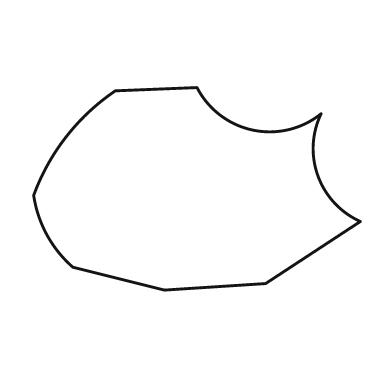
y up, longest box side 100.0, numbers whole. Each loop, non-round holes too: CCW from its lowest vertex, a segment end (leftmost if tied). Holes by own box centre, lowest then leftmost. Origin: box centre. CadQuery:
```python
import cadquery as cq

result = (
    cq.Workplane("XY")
    .moveTo(-10.0, -31.0)
    .lineTo(21.0, -29.0)
    .lineTo(50.0, -10.0)
    .threePointArc((37.0, 4.0), (38.0, 23.0))
    .threePointArc((17.0, 18.0), (0.0, 31.0))
    .lineTo(-25.0, 30.0)
    .threePointArc((-40.0, 16.0), (-50.0, -2.0))
    .threePointArc((-46.0, -14.0), (-38.0, -24.0))
    .close()
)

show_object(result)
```